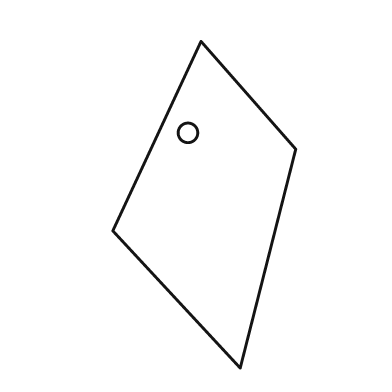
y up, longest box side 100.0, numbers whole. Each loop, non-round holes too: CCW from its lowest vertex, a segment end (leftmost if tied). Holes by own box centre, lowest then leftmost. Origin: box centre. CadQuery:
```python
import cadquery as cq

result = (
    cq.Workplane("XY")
    .moveTo(11.0, -50.0)
    .lineTo(28.0, 17.0)
    .lineTo(-1.0, 50.0)
    .lineTo(-28.0, -8.0)
    .close()
    .moveTo(-5.0, 22.0)
    .circle(3.0)
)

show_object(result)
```